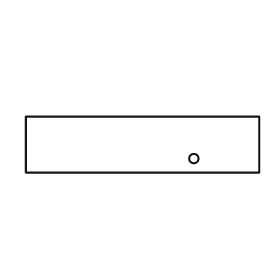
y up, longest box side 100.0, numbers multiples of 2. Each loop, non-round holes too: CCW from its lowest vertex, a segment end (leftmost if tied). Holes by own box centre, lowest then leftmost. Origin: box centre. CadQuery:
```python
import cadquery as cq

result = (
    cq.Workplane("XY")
    .moveTo(-50.0, -12.0)
    .lineTo(50.0, -12.0)
    .lineTo(50.0, 12.0)
    .lineTo(-50.0, 12.0)
    .close()
    .moveTo(22.0, -6.0)
    .circle(2.0)
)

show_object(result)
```